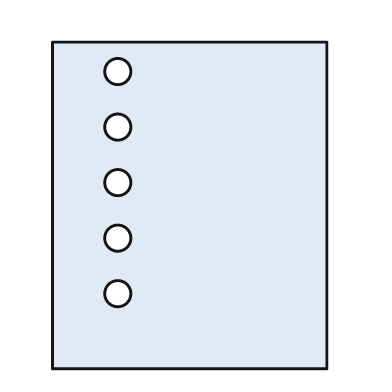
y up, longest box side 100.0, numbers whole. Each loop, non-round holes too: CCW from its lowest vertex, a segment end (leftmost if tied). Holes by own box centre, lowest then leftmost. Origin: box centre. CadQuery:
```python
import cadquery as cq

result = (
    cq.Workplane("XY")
    .moveTo(-42.0, -50.0)
    .lineTo(42.0, -50.0)
    .lineTo(42.0, 50.0)
    .lineTo(-42.0, 50.0)
    .close()
    .moveTo(-22.0, -27.0)
    .circle(4.0)
    .moveTo(-22.0, -10.0)
    .circle(4.0)
    .moveTo(-22.0, 7.0)
    .circle(4.0)
    .moveTo(-22.0, 24.0)
    .circle(4.0)
    .moveTo(-22.0, 41.0)
    .circle(4.0)
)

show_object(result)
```